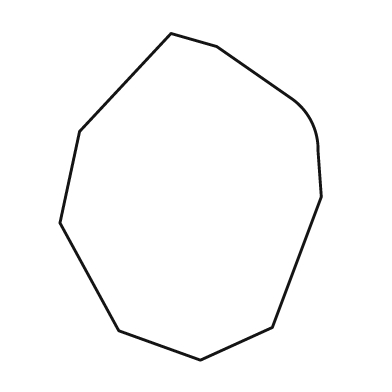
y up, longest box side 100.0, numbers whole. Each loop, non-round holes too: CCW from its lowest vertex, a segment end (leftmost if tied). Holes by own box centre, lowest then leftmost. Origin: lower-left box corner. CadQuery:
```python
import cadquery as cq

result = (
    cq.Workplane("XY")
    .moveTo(43.0, 0.0)
    .lineTo(65.0, 10.0)
    .lineTo(80.0, 50.0)
    .lineTo(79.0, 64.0)
    .threePointArc((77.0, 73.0), (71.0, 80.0))
    .lineTo(48.0, 96.0)
    .lineTo(34.0, 100.0)
    .lineTo(6.0, 70.0)
    .lineTo(0.0, 42.0)
    .lineTo(18.0, 9.0)
    .close()
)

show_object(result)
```